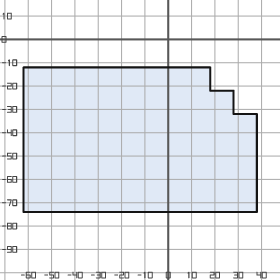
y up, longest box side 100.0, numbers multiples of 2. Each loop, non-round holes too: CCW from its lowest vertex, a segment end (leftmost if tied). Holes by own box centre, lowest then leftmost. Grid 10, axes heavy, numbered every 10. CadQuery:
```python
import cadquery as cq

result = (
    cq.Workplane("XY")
    .moveTo(-62.0, -74.0)
    .lineTo(38.0, -74.0)
    .lineTo(38.0, -32.0)
    .lineTo(28.0, -32.0)
    .lineTo(28.0, -22.0)
    .lineTo(18.0, -22.0)
    .lineTo(18.0, -12.0)
    .lineTo(-62.0, -12.0)
    .close()
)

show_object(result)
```